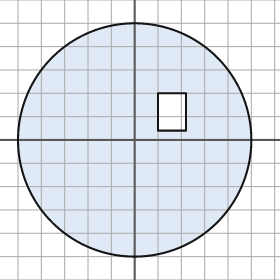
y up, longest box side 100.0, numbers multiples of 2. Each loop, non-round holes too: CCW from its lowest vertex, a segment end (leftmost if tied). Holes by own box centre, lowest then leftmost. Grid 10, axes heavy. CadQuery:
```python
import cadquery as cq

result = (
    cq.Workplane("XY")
    .moveTo(0.0, 0.0)
    .circle(50.0)
    .moveTo(10.0, 4.0)
    .lineTo(22.0, 4.0)
    .lineTo(22.0, 20.0)
    .lineTo(10.0, 20.0)
    .close()
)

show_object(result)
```